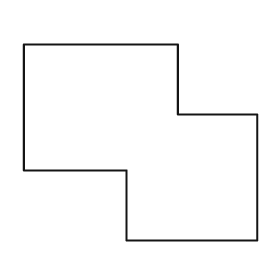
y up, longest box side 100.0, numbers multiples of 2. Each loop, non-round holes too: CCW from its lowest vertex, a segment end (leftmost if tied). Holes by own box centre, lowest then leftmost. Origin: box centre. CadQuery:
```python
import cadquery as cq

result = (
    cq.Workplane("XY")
    .moveTo(-6.0, -42.0)
    .lineTo(50.0, -42.0)
    .lineTo(50.0, 12.0)
    .lineTo(16.0, 12.0)
    .lineTo(16.0, 42.0)
    .lineTo(-50.0, 42.0)
    .lineTo(-50.0, -12.0)
    .lineTo(-6.0, -12.0)
    .close()
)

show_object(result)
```